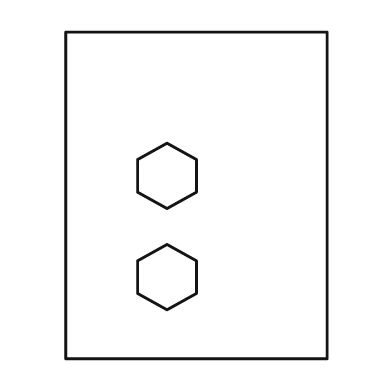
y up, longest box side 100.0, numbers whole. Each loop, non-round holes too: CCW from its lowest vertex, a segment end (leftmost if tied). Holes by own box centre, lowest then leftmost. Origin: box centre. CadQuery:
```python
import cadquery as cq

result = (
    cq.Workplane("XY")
    .moveTo(-40.0, -50.0)
    .lineTo(40.0, -50.0)
    .lineTo(40.0, 50.0)
    .lineTo(-40.0, 50.0)
    .close()
    .moveTo(-9.0, -35.0)
    .lineTo(0.0, -30.0)
    .lineTo(0.0, -20.0)
    .lineTo(-9.0, -15.0)
    .lineTo(-18.0, -20.0)
    .lineTo(-18.0, -30.0)
    .close()
    .moveTo(-9.0, -4.0)
    .lineTo(0.0, 1.0)
    .lineTo(0.0, 11.0)
    .lineTo(-9.0, 16.0)
    .lineTo(-18.0, 11.0)
    .lineTo(-18.0, 1.0)
    .close()
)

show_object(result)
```